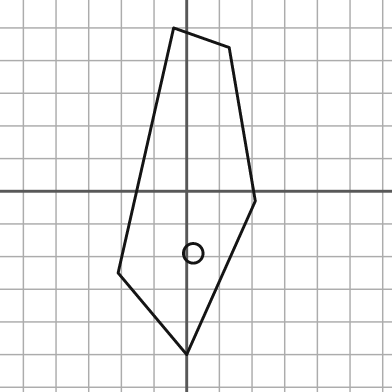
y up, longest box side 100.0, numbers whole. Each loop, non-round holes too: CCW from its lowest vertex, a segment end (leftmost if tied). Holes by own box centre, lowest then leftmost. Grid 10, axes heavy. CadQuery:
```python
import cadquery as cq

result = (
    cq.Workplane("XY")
    .moveTo(0.0, -50.0)
    .lineTo(21.0, -3.0)
    .lineTo(13.0, 44.0)
    .lineTo(-4.0, 50.0)
    .lineTo(-21.0, -25.0)
    .close()
    .moveTo(2.0, -19.0)
    .circle(3.0)
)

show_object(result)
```